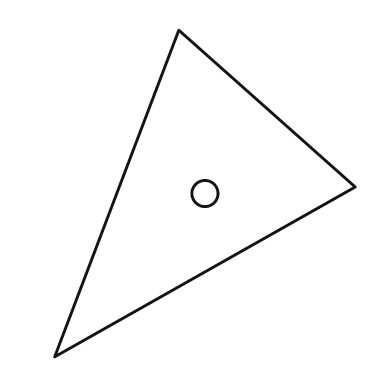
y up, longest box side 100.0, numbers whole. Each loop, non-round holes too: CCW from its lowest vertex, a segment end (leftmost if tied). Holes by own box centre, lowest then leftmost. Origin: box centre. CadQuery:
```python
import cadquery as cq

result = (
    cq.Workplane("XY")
    .moveTo(-46.0, -50.0)
    .lineTo(46.0, 2.0)
    .lineTo(-8.0, 50.0)
    .close()
    .moveTo(0.0, 0.0)
    .circle(4.0)
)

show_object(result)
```